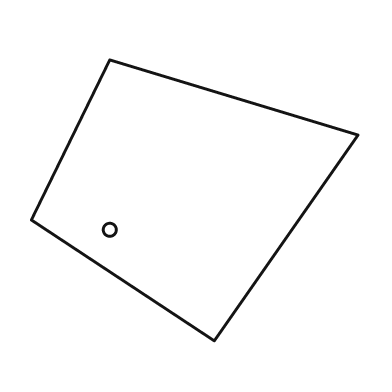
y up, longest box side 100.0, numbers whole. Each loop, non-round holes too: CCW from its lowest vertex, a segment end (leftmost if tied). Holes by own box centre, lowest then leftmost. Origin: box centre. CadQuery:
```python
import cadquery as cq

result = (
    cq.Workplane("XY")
    .moveTo(6.0, -43.0)
    .lineTo(50.0, 20.0)
    .lineTo(-26.0, 43.0)
    .lineTo(-50.0, -6.0)
    .close()
    .moveTo(-26.0, -9.0)
    .circle(2.0)
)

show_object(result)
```